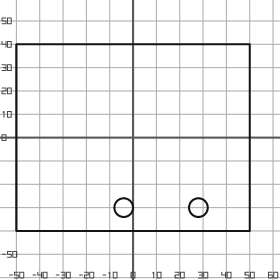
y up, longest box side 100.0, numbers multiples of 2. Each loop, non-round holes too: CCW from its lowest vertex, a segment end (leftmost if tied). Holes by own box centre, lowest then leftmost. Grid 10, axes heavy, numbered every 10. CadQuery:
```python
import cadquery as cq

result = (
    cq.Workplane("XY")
    .moveTo(-50.0, -40.0)
    .lineTo(50.0, -40.0)
    .lineTo(50.0, 40.0)
    .lineTo(-50.0, 40.0)
    .close()
    .moveTo(-4.0, -30.0)
    .circle(4.0)
    .moveTo(28.0, -30.0)
    .circle(4.0)
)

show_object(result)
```